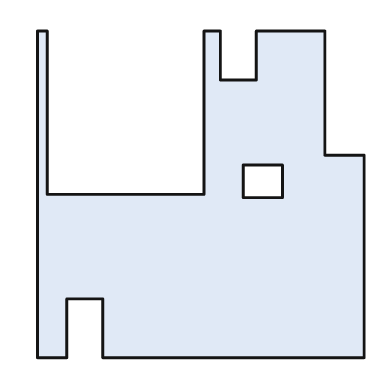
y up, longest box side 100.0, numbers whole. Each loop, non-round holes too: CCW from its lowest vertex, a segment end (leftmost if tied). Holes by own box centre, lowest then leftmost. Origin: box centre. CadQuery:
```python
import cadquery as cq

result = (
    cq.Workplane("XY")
    .moveTo(-50.0, -50.0)
    .lineTo(-41.0, -50.0)
    .lineTo(-41.0, -32.0)
    .lineTo(-30.0, -32.0)
    .lineTo(-30.0, -50.0)
    .lineTo(50.0, -50.0)
    .lineTo(50.0, 12.0)
    .lineTo(38.0, 12.0)
    .lineTo(38.0, 50.0)
    .lineTo(17.0, 50.0)
    .lineTo(17.0, 35.0)
    .lineTo(6.0, 35.0)
    .lineTo(6.0, 50.0)
    .lineTo(1.0, 50.0)
    .lineTo(1.0, 0.0)
    .lineTo(-47.0, 0.0)
    .lineTo(-47.0, 50.0)
    .lineTo(-50.0, 50.0)
    .close()
    .moveTo(13.0, -1.0)
    .lineTo(25.0, -1.0)
    .lineTo(25.0, 9.0)
    .lineTo(13.0, 9.0)
    .close()
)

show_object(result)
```